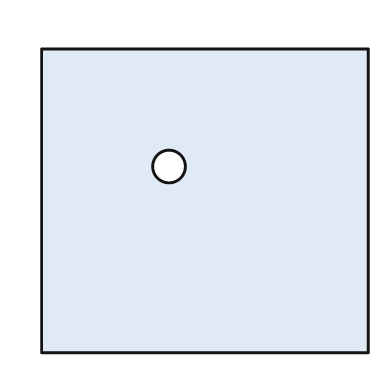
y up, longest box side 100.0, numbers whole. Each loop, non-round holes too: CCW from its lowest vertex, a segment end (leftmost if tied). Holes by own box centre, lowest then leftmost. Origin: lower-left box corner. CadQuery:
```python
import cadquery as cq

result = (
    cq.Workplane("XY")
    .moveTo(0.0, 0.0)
    .lineTo(100.0, 0.0)
    .lineTo(100.0, 93.0)
    .lineTo(0.0, 93.0)
    .close()
    .moveTo(39.0, 57.0)
    .circle(5.0)
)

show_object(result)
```